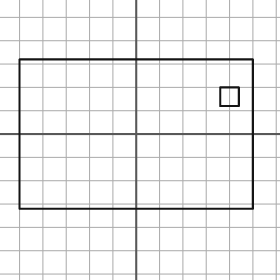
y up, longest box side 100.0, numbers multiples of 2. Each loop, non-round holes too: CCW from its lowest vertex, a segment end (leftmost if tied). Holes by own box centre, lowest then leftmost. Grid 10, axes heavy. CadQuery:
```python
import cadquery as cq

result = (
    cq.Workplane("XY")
    .moveTo(-50.0, -32.0)
    .lineTo(50.0, -32.0)
    .lineTo(50.0, 32.0)
    .lineTo(-50.0, 32.0)
    .close()
    .moveTo(36.0, 12.0)
    .lineTo(44.0, 12.0)
    .lineTo(44.0, 20.0)
    .lineTo(36.0, 20.0)
    .close()
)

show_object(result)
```